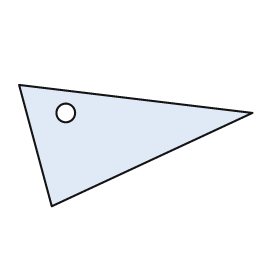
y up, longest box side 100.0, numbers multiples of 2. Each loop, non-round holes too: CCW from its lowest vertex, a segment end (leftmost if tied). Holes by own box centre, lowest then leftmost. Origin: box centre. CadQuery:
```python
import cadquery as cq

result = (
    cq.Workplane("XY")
    .moveTo(-36.0, -26.0)
    .lineTo(50.0, 14.0)
    .lineTo(-50.0, 26.0)
    .close()
    .moveTo(-30.0, 14.0)
    .circle(4.0)
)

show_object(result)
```